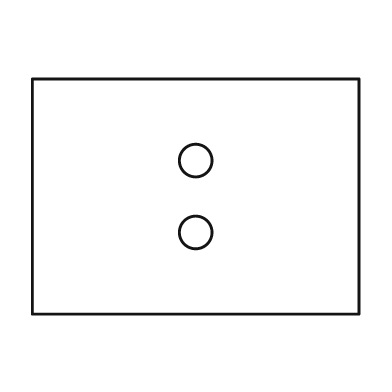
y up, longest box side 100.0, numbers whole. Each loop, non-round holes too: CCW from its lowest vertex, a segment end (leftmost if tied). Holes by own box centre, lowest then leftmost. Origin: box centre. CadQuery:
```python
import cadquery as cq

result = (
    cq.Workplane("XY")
    .moveTo(-50.0, -36.0)
    .lineTo(50.0, -36.0)
    .lineTo(50.0, 36.0)
    .lineTo(-50.0, 36.0)
    .close()
    .moveTo(0.0, -11.0)
    .circle(5.0)
    .moveTo(0.0, 11.0)
    .circle(5.0)
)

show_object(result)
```